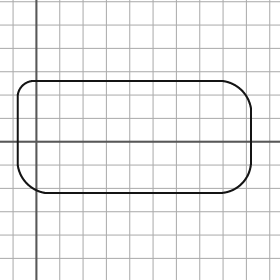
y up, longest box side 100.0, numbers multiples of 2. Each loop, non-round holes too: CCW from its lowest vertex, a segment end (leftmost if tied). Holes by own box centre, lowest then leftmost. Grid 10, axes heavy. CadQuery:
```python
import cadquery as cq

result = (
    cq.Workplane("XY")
    .moveTo(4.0, -22.0)
    .lineTo(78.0, -22.0)
    .threePointArc((88.0, -18.0), (92.0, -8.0))
    .lineTo(92.0, 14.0)
    .threePointArc((88.0, 22.0), (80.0, 26.0))
    .lineTo(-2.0, 26.0)
    .threePointArc((-6.0, 24.0), (-8.0, 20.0))
    .lineTo(-8.0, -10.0)
    .threePointArc((-4.0, -18.0), (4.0, -22.0))
    .close()
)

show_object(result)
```